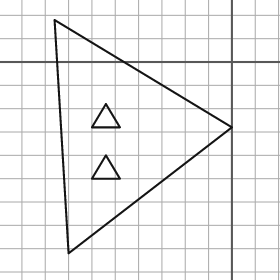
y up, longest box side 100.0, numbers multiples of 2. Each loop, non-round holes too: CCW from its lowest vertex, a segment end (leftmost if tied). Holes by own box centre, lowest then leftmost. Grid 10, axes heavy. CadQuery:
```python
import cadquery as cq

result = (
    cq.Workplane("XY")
    .moveTo(-70.0, -82.0)
    .lineTo(0.0, -28.0)
    .lineTo(-76.0, 18.0)
    .close()
    .moveTo(-60.0, -50.0)
    .lineTo(-48.0, -50.0)
    .lineTo(-54.0, -40.0)
    .close()
    .moveTo(-60.0, -28.0)
    .lineTo(-48.0, -28.0)
    .lineTo(-54.0, -18.0)
    .close()
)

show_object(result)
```